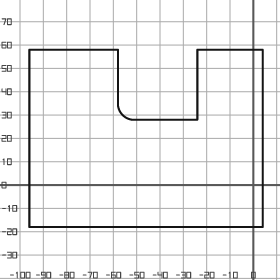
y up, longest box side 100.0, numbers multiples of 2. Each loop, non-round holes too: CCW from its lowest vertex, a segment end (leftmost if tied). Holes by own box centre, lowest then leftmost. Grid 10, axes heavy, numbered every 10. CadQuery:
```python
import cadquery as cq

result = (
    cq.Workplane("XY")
    .moveTo(-96.0, -18.0)
    .lineTo(4.0, -18.0)
    .lineTo(4.0, 58.0)
    .lineTo(-24.0, 58.0)
    .lineTo(-24.0, 28.0)
    .lineTo(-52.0, 28.0)
    .threePointArc((-56.0, 30.0), (-58.0, 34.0))
    .lineTo(-58.0, 58.0)
    .lineTo(-96.0, 58.0)
    .close()
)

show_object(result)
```